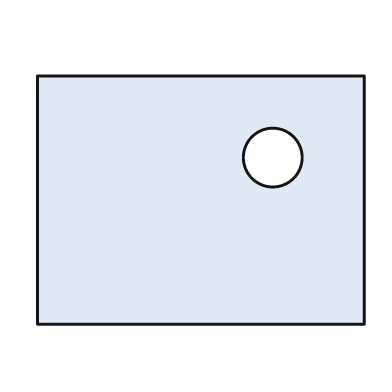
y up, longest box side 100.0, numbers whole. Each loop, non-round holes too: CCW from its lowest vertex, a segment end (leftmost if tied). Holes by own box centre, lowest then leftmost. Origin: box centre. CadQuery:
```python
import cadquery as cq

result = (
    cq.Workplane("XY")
    .moveTo(-50.0, -38.0)
    .lineTo(50.0, -38.0)
    .lineTo(50.0, 38.0)
    .lineTo(-50.0, 38.0)
    .close()
    .moveTo(22.0, 13.0)
    .circle(9.0)
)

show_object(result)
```